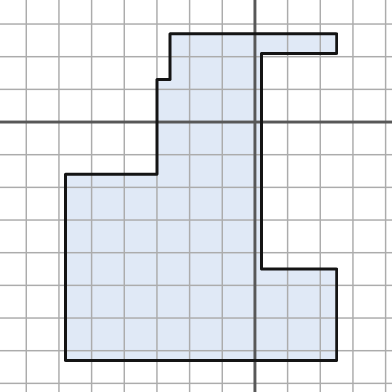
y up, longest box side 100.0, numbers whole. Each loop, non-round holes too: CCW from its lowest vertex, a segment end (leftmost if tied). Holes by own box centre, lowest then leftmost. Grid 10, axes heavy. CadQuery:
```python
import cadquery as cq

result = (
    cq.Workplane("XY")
    .moveTo(-58.0, -73.0)
    .lineTo(25.0, -73.0)
    .lineTo(25.0, -45.0)
    .lineTo(2.0, -45.0)
    .lineTo(2.0, 21.0)
    .lineTo(25.0, 21.0)
    .lineTo(25.0, 27.0)
    .lineTo(-26.0, 27.0)
    .lineTo(-26.0, 13.0)
    .lineTo(-30.0, 13.0)
    .lineTo(-30.0, -16.0)
    .lineTo(-58.0, -16.0)
    .close()
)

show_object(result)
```